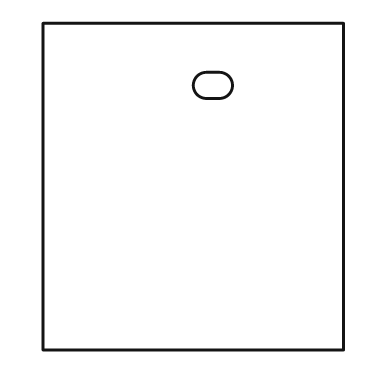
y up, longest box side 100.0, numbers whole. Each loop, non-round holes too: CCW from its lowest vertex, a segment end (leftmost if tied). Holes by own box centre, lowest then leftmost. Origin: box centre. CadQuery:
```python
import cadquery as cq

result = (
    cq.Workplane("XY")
    .moveTo(-46.0, -50.0)
    .lineTo(46.0, -50.0)
    .lineTo(46.0, 50.0)
    .lineTo(-46.0, 50.0)
    .close()
    .moveTo(4.0, 27.0)
    .lineTo(8.0, 27.0)
    .threePointArc((12.0, 31.0), (8.0, 35.0))
    .lineTo(4.0, 35.0)
    .threePointArc((0.0, 31.0), (4.0, 27.0))
    .close()
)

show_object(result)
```